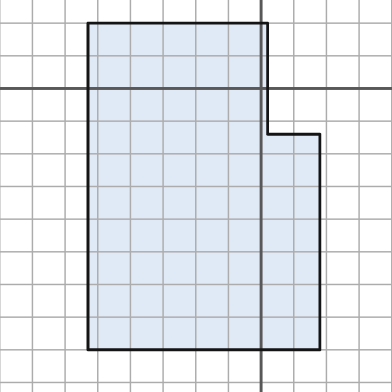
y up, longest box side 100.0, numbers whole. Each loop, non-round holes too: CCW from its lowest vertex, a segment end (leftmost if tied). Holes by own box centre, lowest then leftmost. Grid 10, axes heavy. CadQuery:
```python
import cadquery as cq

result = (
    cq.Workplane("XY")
    .moveTo(-53.0, -80.0)
    .lineTo(18.0, -80.0)
    .lineTo(18.0, -14.0)
    .lineTo(2.0, -14.0)
    .lineTo(2.0, 20.0)
    .lineTo(-53.0, 20.0)
    .close()
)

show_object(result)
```